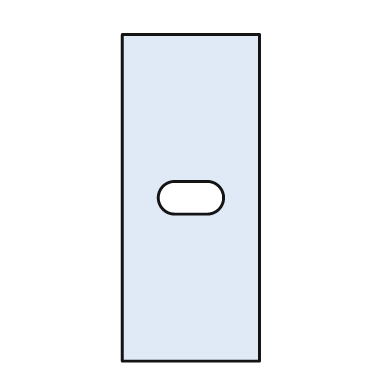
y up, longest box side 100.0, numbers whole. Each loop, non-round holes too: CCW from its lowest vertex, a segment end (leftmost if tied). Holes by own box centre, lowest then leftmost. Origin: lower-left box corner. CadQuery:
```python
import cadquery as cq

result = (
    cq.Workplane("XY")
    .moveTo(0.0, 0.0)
    .lineTo(42.0, 0.0)
    .lineTo(42.0, 100.0)
    .lineTo(0.0, 100.0)
    .close()
    .moveTo(16.0, 45.0)
    .lineTo(26.0, 45.0)
    .threePointArc((31.0, 50.0), (26.0, 55.0))
    .lineTo(16.0, 55.0)
    .threePointArc((11.0, 50.0), (16.0, 45.0))
    .close()
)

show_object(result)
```